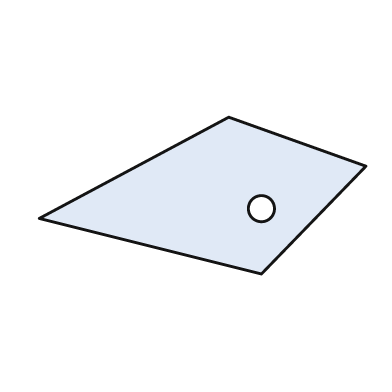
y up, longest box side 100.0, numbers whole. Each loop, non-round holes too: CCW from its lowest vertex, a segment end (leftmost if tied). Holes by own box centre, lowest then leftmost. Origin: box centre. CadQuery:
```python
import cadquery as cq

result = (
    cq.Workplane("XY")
    .moveTo(18.0, -24.0)
    .lineTo(50.0, 9.0)
    .lineTo(8.0, 24.0)
    .lineTo(-50.0, -7.0)
    .close()
    .moveTo(18.0, -4.0)
    .circle(4.0)
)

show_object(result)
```